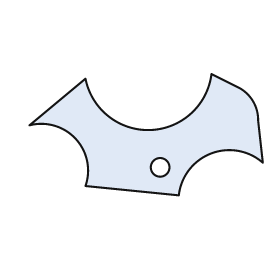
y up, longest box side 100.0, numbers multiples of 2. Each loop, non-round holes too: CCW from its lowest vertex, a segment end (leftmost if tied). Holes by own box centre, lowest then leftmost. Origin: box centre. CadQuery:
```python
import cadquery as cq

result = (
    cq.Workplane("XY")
    .moveTo(14.0, -26.0)
    .threePointArc((28.0, -8.0), (50.0, -12.0))
    .lineTo(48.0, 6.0)
    .threePointArc((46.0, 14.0), (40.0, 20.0))
    .lineTo(28.0, 26.0)
    .threePointArc((2.0, 2.0), (-26.0, 24.0))
    .lineTo(-50.0, 4.0)
    .threePointArc((-30.0, -2.0), (-26.0, -22.0))
    .close()
    .moveTo(6.0, -14.0)
    .circle(4.0)
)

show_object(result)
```